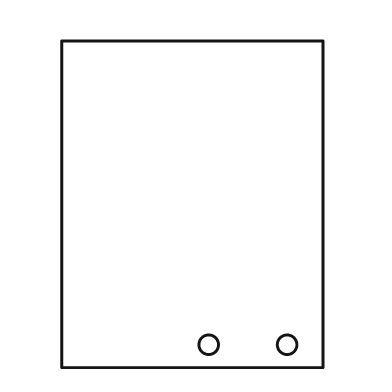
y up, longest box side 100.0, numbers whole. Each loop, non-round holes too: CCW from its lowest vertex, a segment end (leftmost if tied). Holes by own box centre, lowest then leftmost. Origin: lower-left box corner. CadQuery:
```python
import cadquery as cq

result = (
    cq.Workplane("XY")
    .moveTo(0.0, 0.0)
    .lineTo(80.0, 0.0)
    .lineTo(80.0, 100.0)
    .lineTo(0.0, 100.0)
    .close()
    .moveTo(45.0, 7.0)
    .circle(3.0)
    .moveTo(69.0, 7.0)
    .circle(3.0)
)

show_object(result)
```